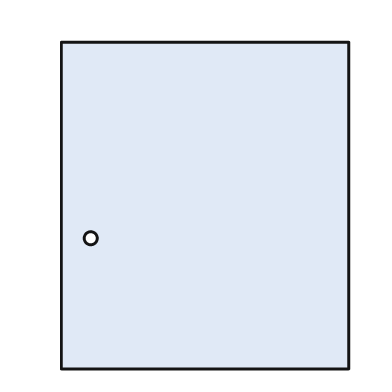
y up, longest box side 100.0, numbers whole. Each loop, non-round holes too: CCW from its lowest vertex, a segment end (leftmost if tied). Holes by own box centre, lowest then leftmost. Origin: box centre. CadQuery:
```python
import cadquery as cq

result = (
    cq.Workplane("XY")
    .moveTo(-44.0, -50.0)
    .lineTo(44.0, -50.0)
    .lineTo(44.0, 50.0)
    .lineTo(-44.0, 50.0)
    .close()
    .moveTo(-35.0, -10.0)
    .circle(2.0)
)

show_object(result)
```